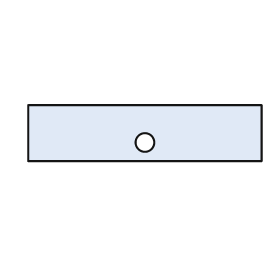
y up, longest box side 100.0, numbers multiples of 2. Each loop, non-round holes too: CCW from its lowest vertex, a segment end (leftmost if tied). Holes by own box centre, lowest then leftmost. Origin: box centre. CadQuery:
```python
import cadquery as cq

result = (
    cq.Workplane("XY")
    .moveTo(-50.0, -12.0)
    .lineTo(50.0, -12.0)
    .lineTo(50.0, 12.0)
    .lineTo(-50.0, 12.0)
    .close()
    .moveTo(0.0, -4.0)
    .circle(4.0)
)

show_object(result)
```